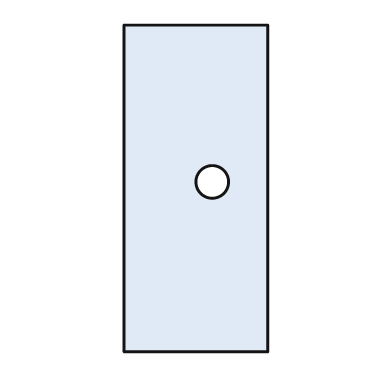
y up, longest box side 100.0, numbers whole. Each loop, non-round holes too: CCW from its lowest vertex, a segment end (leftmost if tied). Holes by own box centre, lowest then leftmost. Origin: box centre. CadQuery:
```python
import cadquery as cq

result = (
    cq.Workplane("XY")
    .moveTo(-22.0, -50.0)
    .lineTo(22.0, -50.0)
    .lineTo(22.0, 50.0)
    .lineTo(-22.0, 50.0)
    .close()
    .moveTo(5.0, 2.0)
    .circle(5.0)
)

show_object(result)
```